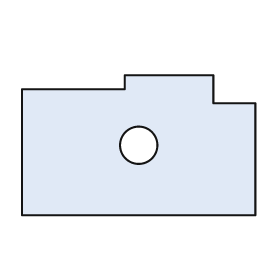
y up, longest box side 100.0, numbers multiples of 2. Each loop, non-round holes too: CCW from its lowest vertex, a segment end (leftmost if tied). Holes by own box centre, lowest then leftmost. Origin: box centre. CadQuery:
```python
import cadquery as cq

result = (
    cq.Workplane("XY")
    .moveTo(-50.0, -30.0)
    .lineTo(50.0, -30.0)
    .lineTo(50.0, 18.0)
    .lineTo(32.0, 18.0)
    .lineTo(32.0, 30.0)
    .lineTo(-6.0, 30.0)
    .lineTo(-6.0, 24.0)
    .lineTo(-50.0, 24.0)
    .close()
    .moveTo(0.0, 0.0)
    .circle(8.0)
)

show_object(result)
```